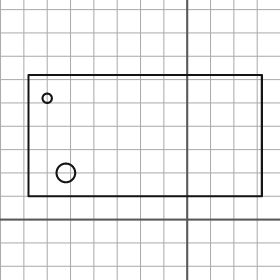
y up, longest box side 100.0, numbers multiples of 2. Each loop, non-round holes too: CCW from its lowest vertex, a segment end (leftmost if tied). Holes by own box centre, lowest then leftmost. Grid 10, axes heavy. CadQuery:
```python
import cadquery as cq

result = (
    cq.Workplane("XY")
    .moveTo(-68.0, 10.0)
    .lineTo(32.0, 10.0)
    .lineTo(32.0, 62.0)
    .lineTo(-68.0, 62.0)
    .close()
    .moveTo(-52.0, 20.0)
    .circle(4.0)
    .moveTo(-60.0, 52.0)
    .circle(2.0)
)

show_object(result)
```